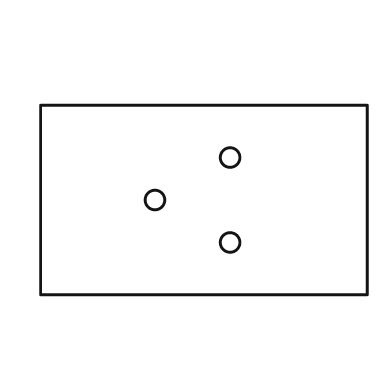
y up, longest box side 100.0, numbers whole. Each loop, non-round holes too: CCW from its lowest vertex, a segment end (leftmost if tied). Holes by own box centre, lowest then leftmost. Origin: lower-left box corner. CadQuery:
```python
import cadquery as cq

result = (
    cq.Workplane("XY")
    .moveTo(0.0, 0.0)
    .lineTo(100.0, 0.0)
    .lineTo(100.0, 58.0)
    .lineTo(0.0, 58.0)
    .close()
    .moveTo(58.0, 16.0)
    .circle(3.0)
    .moveTo(35.0, 29.0)
    .circle(3.0)
    .moveTo(58.0, 42.0)
    .circle(3.0)
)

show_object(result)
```